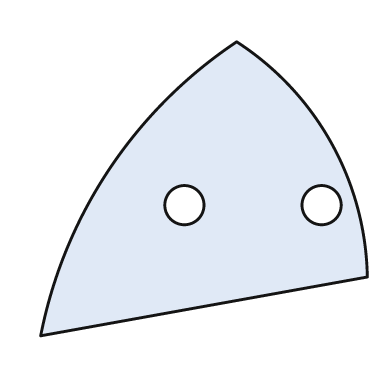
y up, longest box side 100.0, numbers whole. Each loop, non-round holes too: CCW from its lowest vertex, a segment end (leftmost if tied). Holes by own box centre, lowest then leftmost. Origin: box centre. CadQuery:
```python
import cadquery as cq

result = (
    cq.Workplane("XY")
    .moveTo(-50.0, -45.0)
    .lineTo(50.0, -27.0)
    .threePointArc((39.0, 14.0), (10.0, 45.0))
    .threePointArc((-29.0, 6.0), (-50.0, -45.0))
    .close()
    .moveTo(-6.0, -5.0)
    .circle(6.0)
    .moveTo(36.0, -5.0)
    .circle(6.0)
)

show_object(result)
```